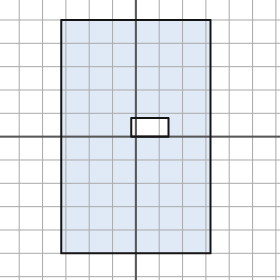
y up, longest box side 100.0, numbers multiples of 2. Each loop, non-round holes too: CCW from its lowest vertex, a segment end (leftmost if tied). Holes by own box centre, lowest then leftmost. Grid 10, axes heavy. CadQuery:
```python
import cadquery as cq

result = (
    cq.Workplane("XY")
    .moveTo(-32.0, -50.0)
    .lineTo(32.0, -50.0)
    .lineTo(32.0, 50.0)
    .lineTo(-32.0, 50.0)
    .close()
    .moveTo(-2.0, 0.0)
    .lineTo(14.0, 0.0)
    .lineTo(14.0, 8.0)
    .lineTo(-2.0, 8.0)
    .close()
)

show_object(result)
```